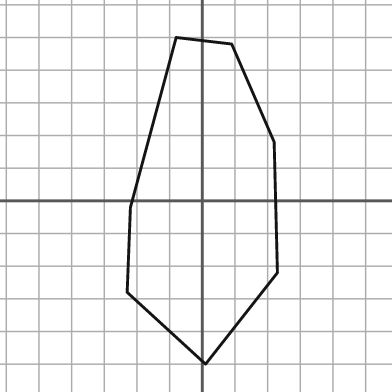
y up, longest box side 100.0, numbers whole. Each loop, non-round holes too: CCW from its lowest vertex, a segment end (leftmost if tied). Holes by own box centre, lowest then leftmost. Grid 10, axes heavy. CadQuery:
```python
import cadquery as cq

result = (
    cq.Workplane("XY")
    .moveTo(1.0, -50.0)
    .lineTo(23.0, -22.0)
    .lineTo(22.0, 18.0)
    .lineTo(9.0, 48.0)
    .lineTo(-8.0, 50.0)
    .lineTo(-22.0, -2.0)
    .lineTo(-23.0, -28.0)
    .close()
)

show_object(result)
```